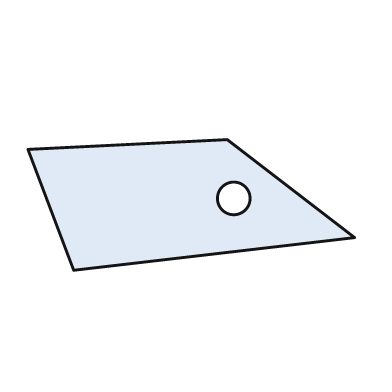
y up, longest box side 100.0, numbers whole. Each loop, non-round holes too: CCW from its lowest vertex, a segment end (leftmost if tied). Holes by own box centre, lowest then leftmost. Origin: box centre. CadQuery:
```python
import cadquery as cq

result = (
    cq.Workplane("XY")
    .moveTo(-36.0, -20.0)
    .lineTo(50.0, -10.0)
    .lineTo(11.0, 20.0)
    .lineTo(-50.0, 17.0)
    .close()
    .moveTo(13.0, 2.0)
    .circle(5.0)
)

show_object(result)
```